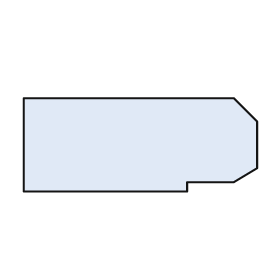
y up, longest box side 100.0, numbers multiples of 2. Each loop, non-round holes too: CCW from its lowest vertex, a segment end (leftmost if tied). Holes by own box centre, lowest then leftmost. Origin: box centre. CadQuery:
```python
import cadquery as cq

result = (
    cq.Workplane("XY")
    .moveTo(-50.0, -20.0)
    .lineTo(20.0, -20.0)
    .lineTo(20.0, -16.0)
    .lineTo(40.0, -16.0)
    .lineTo(50.0, -10.0)
    .lineTo(50.0, 10.0)
    .lineTo(40.0, 20.0)
    .lineTo(-50.0, 20.0)
    .close()
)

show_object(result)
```